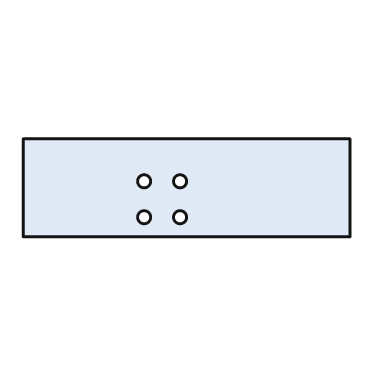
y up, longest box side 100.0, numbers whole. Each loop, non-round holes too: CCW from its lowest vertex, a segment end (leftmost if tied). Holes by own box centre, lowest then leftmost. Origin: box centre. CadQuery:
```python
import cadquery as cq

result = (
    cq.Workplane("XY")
    .moveTo(-50.0, -15.0)
    .lineTo(50.0, -15.0)
    .lineTo(50.0, 15.0)
    .lineTo(-50.0, 15.0)
    .close()
    .moveTo(-13.0, -9.0)
    .circle(2.0)
    .moveTo(-2.0, -9.0)
    .circle(2.0)
    .moveTo(-13.0, 2.0)
    .circle(2.0)
    .moveTo(-2.0, 2.0)
    .circle(2.0)
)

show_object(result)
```